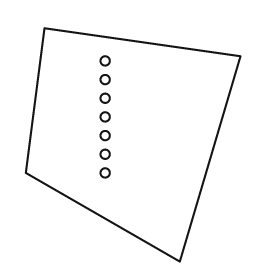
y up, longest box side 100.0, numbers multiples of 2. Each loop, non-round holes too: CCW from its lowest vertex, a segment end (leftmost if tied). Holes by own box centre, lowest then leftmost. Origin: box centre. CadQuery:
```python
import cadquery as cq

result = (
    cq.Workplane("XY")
    .moveTo(20.0, -50.0)
    .lineTo(46.0, 38.0)
    .lineTo(-38.0, 50.0)
    .lineTo(-46.0, -12.0)
    .close()
    .moveTo(-12.0, -12.0)
    .circle(2.0)
    .moveTo(-12.0, -4.0)
    .circle(2.0)
    .moveTo(-12.0, 4.0)
    .circle(2.0)
    .moveTo(-12.0, 12.0)
    .circle(2.0)
    .moveTo(-12.0, 20.0)
    .circle(2.0)
    .moveTo(-12.0, 28.0)
    .circle(2.0)
    .moveTo(-12.0, 36.0)
    .circle(2.0)
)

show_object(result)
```